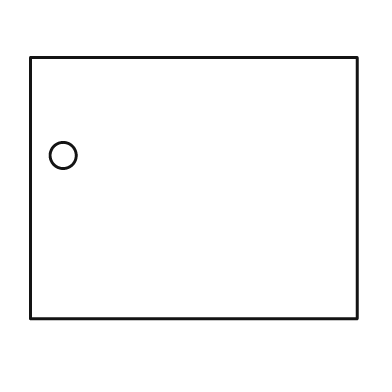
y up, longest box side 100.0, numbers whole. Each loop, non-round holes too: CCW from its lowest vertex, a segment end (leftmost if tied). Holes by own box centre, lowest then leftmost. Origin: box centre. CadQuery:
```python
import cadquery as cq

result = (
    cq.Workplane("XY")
    .moveTo(-50.0, -40.0)
    .lineTo(50.0, -40.0)
    .lineTo(50.0, 40.0)
    .lineTo(-50.0, 40.0)
    .close()
    .moveTo(-40.0, 10.0)
    .circle(4.0)
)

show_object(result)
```